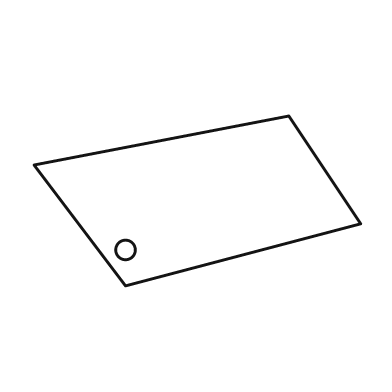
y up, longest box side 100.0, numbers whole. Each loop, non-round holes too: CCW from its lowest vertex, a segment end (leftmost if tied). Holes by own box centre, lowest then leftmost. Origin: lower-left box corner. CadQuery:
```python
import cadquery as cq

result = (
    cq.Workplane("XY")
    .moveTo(28.0, 0.0)
    .lineTo(100.0, 19.0)
    .lineTo(78.0, 52.0)
    .lineTo(0.0, 37.0)
    .close()
    .moveTo(28.0, 11.0)
    .circle(3.0)
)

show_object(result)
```